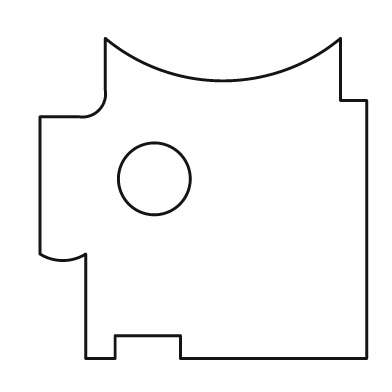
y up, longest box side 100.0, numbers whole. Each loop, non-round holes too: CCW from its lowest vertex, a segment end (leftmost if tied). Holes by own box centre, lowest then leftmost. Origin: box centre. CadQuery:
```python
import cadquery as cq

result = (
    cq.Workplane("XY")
    .moveTo(-36.0, -49.0)
    .lineTo(-27.0, -49.0)
    .lineTo(-27.0, -42.0)
    .lineTo(-7.0, -42.0)
    .lineTo(-7.0, -49.0)
    .lineTo(50.0, -49.0)
    .lineTo(50.0, 30.0)
    .lineTo(42.0, 30.0)
    .lineTo(42.0, 49.0)
    .threePointArc((6.0, 36.0), (-30.0, 49.0))
    .lineTo(-30.0, 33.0)
    .threePointArc((-32.0, 27.0), (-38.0, 25.0))
    .lineTo(-50.0, 25.0)
    .lineTo(-50.0, -17.0)
    .threePointArc((-43.0, -19.0), (-36.0, -17.0))
    .close()
    .moveTo(-15.0, 6.0)
    .circle(11.0)
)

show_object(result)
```